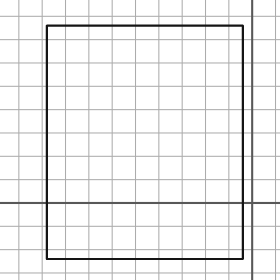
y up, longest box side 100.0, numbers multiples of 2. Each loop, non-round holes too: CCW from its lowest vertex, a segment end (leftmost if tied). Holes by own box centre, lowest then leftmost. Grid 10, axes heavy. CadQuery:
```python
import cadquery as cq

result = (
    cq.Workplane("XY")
    .moveTo(-88.0, -24.0)
    .lineTo(-4.0, -24.0)
    .lineTo(-4.0, 76.0)
    .lineTo(-88.0, 76.0)
    .close()
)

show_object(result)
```